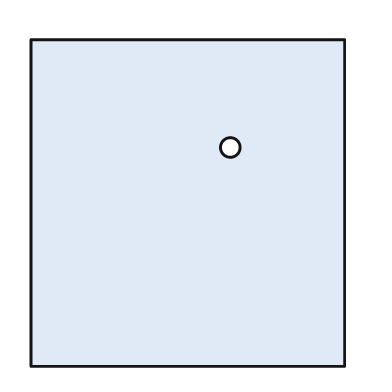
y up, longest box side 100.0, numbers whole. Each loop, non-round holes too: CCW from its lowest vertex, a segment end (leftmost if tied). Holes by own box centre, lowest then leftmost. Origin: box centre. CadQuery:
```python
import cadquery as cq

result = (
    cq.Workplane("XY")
    .moveTo(-48.0, -50.0)
    .lineTo(48.0, -50.0)
    .lineTo(48.0, 50.0)
    .lineTo(-48.0, 50.0)
    .close()
    .moveTo(13.0, 17.0)
    .circle(3.0)
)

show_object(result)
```